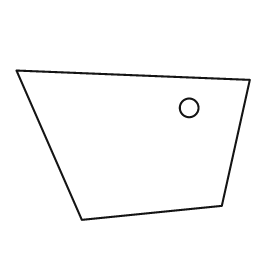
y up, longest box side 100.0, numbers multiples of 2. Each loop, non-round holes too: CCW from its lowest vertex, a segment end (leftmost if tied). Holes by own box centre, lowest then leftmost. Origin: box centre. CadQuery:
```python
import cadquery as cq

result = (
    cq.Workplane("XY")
    .moveTo(-22.0, -32.0)
    .lineTo(38.0, -26.0)
    .lineTo(50.0, 28.0)
    .lineTo(-50.0, 32.0)
    .close()
    .moveTo(24.0, 16.0)
    .circle(4.0)
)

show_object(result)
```